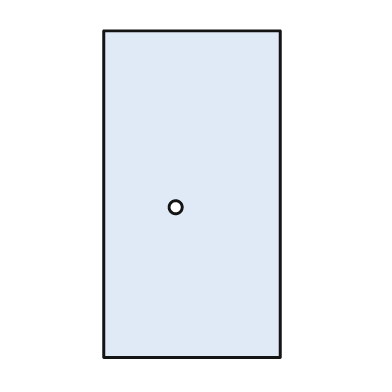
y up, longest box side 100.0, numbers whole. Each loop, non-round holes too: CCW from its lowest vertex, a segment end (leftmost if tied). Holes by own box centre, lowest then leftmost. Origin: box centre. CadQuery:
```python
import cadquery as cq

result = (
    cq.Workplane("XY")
    .moveTo(-27.0, -50.0)
    .lineTo(27.0, -50.0)
    .lineTo(27.0, 50.0)
    .lineTo(-27.0, 50.0)
    .close()
    .moveTo(-5.0, -4.0)
    .circle(2.0)
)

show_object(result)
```